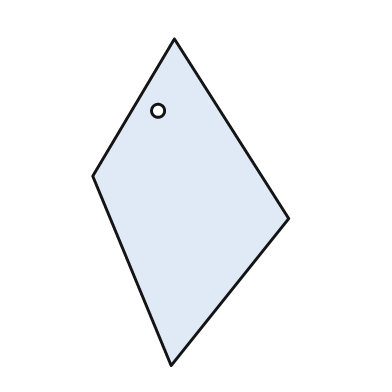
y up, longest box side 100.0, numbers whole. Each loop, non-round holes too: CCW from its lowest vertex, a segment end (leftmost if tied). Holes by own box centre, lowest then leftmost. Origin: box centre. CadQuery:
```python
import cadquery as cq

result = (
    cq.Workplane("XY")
    .moveTo(-6.0, -50.0)
    .lineTo(30.0, -5.0)
    .lineTo(-5.0, 50.0)
    .lineTo(-30.0, 8.0)
    .close()
    .moveTo(-10.0, 28.0)
    .circle(2.0)
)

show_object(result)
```